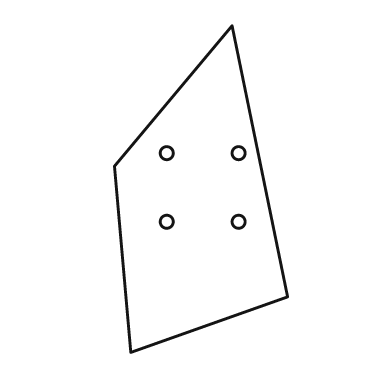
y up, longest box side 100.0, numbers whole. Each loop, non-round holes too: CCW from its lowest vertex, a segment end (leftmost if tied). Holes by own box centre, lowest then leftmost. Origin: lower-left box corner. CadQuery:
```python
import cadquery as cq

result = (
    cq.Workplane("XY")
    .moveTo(5.0, 0.0)
    .lineTo(53.0, 17.0)
    .lineTo(36.0, 100.0)
    .lineTo(0.0, 57.0)
    .close()
    .moveTo(16.0, 40.0)
    .circle(2.0)
    .moveTo(38.0, 40.0)
    .circle(2.0)
    .moveTo(16.0, 61.0)
    .circle(2.0)
    .moveTo(38.0, 61.0)
    .circle(2.0)
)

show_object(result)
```